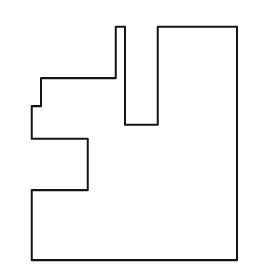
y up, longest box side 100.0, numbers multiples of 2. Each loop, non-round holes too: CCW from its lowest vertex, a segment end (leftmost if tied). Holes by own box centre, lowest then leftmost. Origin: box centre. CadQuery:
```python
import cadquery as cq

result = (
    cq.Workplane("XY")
    .moveTo(-44.0, -50.0)
    .lineTo(44.0, -50.0)
    .lineTo(44.0, 50.0)
    .lineTo(10.0, 50.0)
    .lineTo(10.0, 8.0)
    .lineTo(-4.0, 8.0)
    .lineTo(-4.0, 50.0)
    .lineTo(-8.0, 50.0)
    .lineTo(-8.0, 28.0)
    .lineTo(-40.0, 28.0)
    .lineTo(-40.0, 16.0)
    .lineTo(-44.0, 16.0)
    .lineTo(-44.0, 2.0)
    .lineTo(-20.0, 2.0)
    .lineTo(-20.0, -20.0)
    .lineTo(-44.0, -20.0)
    .close()
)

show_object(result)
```